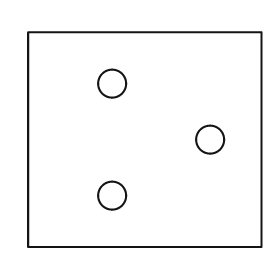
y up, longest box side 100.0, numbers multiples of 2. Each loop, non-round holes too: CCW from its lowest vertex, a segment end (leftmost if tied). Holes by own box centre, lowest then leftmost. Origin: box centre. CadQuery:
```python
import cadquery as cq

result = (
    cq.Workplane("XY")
    .moveTo(-50.0, -46.0)
    .lineTo(50.0, -46.0)
    .lineTo(50.0, 46.0)
    .lineTo(-50.0, 46.0)
    .close()
    .moveTo(-14.0, -24.0)
    .circle(6.0)
    .moveTo(28.0, 0.0)
    .circle(6.0)
    .moveTo(-14.0, 24.0)
    .circle(6.0)
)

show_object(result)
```